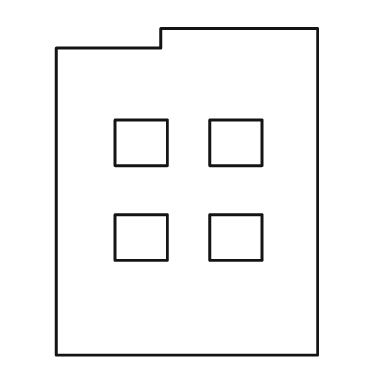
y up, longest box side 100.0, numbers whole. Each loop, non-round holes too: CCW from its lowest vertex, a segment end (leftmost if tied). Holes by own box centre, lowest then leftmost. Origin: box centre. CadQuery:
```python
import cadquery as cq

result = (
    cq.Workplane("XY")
    .moveTo(-40.0, -50.0)
    .lineTo(40.0, -50.0)
    .lineTo(40.0, 50.0)
    .lineTo(-8.0, 50.0)
    .lineTo(-8.0, 44.0)
    .lineTo(-40.0, 44.0)
    .close()
    .moveTo(-22.0, -21.0)
    .lineTo(-6.0, -21.0)
    .lineTo(-6.0, -7.0)
    .lineTo(-22.0, -7.0)
    .close()
    .moveTo(7.0, -21.0)
    .lineTo(23.0, -21.0)
    .lineTo(23.0, -7.0)
    .lineTo(7.0, -7.0)
    .close()
    .moveTo(-22.0, 8.0)
    .lineTo(-6.0, 8.0)
    .lineTo(-6.0, 22.0)
    .lineTo(-22.0, 22.0)
    .close()
    .moveTo(7.0, 8.0)
    .lineTo(23.0, 8.0)
    .lineTo(23.0, 22.0)
    .lineTo(7.0, 22.0)
    .close()
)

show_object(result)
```